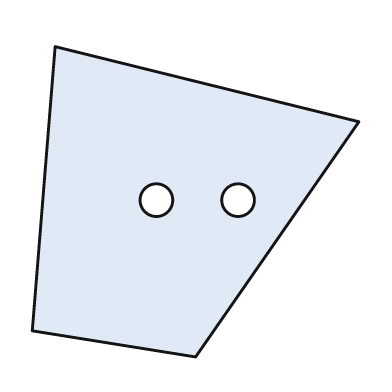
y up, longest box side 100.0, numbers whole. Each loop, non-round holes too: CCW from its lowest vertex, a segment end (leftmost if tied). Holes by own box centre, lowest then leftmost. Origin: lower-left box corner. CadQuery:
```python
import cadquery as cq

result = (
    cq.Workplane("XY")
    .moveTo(50.0, 0.0)
    .lineTo(100.0, 72.0)
    .lineTo(7.0, 95.0)
    .lineTo(0.0, 8.0)
    .close()
    .moveTo(38.0, 48.0)
    .circle(5.0)
    .moveTo(63.0, 48.0)
    .circle(5.0)
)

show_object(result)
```